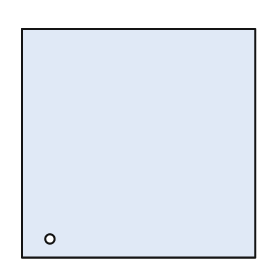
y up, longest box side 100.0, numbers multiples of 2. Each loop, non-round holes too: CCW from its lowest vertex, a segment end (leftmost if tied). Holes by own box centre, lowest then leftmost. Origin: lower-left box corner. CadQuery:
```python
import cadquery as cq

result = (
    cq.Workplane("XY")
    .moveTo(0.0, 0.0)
    .lineTo(100.0, 0.0)
    .lineTo(100.0, 98.0)
    .lineTo(0.0, 98.0)
    .close()
    .moveTo(12.0, 8.0)
    .circle(2.0)
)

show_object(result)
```